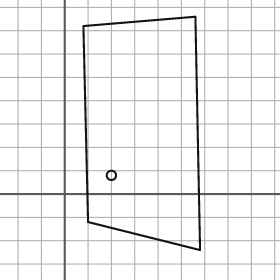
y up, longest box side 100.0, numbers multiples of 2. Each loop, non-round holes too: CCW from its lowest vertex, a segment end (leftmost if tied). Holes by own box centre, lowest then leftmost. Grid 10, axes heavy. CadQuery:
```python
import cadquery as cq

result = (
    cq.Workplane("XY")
    .moveTo(58.0, -24.0)
    .lineTo(56.0, 76.0)
    .lineTo(8.0, 72.0)
    .lineTo(10.0, -12.0)
    .close()
    .moveTo(20.0, 8.0)
    .circle(2.0)
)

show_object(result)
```